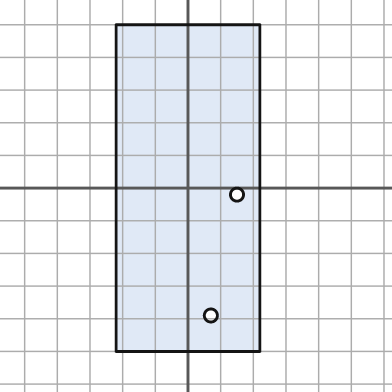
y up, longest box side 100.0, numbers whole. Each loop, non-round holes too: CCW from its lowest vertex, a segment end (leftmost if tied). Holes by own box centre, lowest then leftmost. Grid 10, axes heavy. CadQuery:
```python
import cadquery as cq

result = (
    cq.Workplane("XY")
    .moveTo(-22.0, -50.0)
    .lineTo(22.0, -50.0)
    .lineTo(22.0, 50.0)
    .lineTo(-22.0, 50.0)
    .close()
    .moveTo(7.0, -39.0)
    .circle(2.0)
    .moveTo(15.0, -2.0)
    .circle(2.0)
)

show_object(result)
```